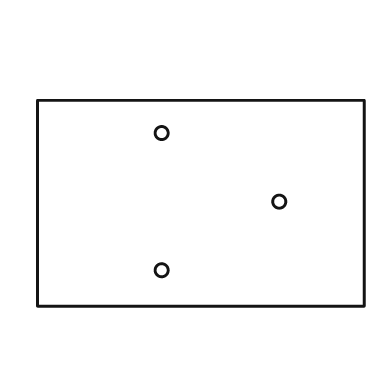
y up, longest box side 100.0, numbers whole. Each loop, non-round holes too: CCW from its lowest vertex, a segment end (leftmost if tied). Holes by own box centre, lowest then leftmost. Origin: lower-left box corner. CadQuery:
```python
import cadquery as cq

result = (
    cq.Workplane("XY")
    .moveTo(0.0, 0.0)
    .lineTo(100.0, 0.0)
    .lineTo(100.0, 63.0)
    .lineTo(0.0, 63.0)
    .close()
    .moveTo(38.0, 11.0)
    .circle(2.0)
    .moveTo(74.0, 32.0)
    .circle(2.0)
    .moveTo(38.0, 53.0)
    .circle(2.0)
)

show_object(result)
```